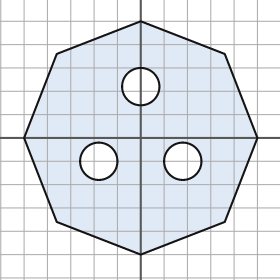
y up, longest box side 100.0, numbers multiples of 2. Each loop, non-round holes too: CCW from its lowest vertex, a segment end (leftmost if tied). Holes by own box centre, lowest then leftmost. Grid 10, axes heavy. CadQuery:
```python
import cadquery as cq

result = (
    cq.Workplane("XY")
    .moveTo(0.0, -50.0)
    .lineTo(36.0, -36.0)
    .lineTo(50.0, 0.0)
    .lineTo(36.0, 36.0)
    .lineTo(0.0, 50.0)
    .lineTo(-36.0, 36.0)
    .lineTo(-50.0, 0.0)
    .lineTo(-36.0, -36.0)
    .close()
    .moveTo(-18.0, -10.0)
    .circle(8.0)
    .moveTo(18.0, -10.0)
    .circle(8.0)
    .moveTo(0.0, 22.0)
    .circle(8.0)
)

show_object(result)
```